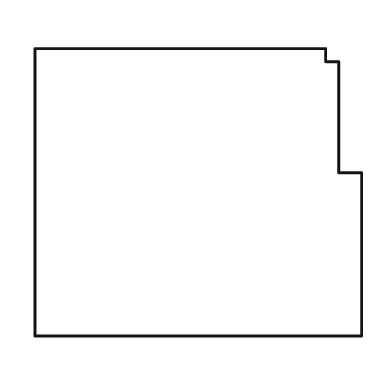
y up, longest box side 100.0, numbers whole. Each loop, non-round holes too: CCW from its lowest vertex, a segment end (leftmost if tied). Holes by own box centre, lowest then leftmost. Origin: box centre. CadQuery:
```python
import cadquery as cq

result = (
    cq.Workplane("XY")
    .moveTo(-50.0, -44.0)
    .lineTo(50.0, -44.0)
    .lineTo(50.0, 6.0)
    .lineTo(43.0, 6.0)
    .lineTo(43.0, 40.0)
    .lineTo(39.0, 40.0)
    .lineTo(39.0, 44.0)
    .lineTo(-50.0, 44.0)
    .close()
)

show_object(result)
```